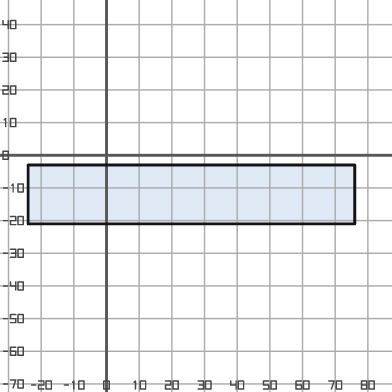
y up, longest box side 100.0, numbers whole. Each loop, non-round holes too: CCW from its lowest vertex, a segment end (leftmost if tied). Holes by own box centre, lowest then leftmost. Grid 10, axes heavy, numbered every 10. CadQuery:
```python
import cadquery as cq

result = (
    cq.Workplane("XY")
    .moveTo(-24.0, -21.0)
    .lineTo(76.0, -21.0)
    .lineTo(76.0, -3.0)
    .lineTo(-24.0, -3.0)
    .close()
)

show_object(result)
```